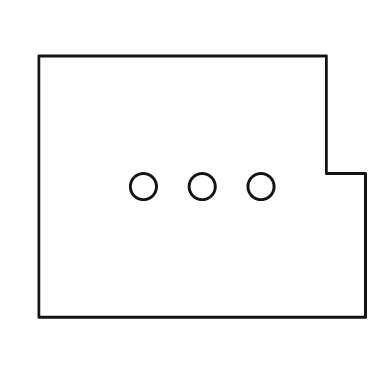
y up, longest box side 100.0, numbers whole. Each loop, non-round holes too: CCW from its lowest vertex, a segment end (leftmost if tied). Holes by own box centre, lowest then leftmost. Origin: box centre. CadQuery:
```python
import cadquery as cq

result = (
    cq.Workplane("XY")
    .moveTo(-50.0, -40.0)
    .lineTo(50.0, -40.0)
    .lineTo(50.0, 4.0)
    .lineTo(38.0, 4.0)
    .lineTo(38.0, 40.0)
    .lineTo(-50.0, 40.0)
    .close()
    .moveTo(-18.0, 0.0)
    .circle(4.0)
    .moveTo(0.0, 0.0)
    .circle(4.0)
    .moveTo(18.0, 0.0)
    .circle(4.0)
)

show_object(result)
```